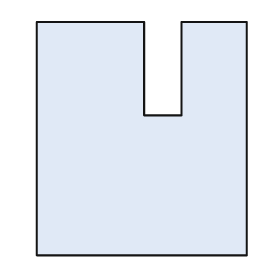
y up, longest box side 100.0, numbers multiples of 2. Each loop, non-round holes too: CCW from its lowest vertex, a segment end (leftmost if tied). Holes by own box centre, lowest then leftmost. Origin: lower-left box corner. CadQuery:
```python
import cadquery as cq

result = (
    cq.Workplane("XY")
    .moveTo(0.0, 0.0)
    .lineTo(90.0, 0.0)
    .lineTo(90.0, 100.0)
    .lineTo(62.0, 100.0)
    .lineTo(62.0, 60.0)
    .lineTo(46.0, 60.0)
    .lineTo(46.0, 100.0)
    .lineTo(0.0, 100.0)
    .close()
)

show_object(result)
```